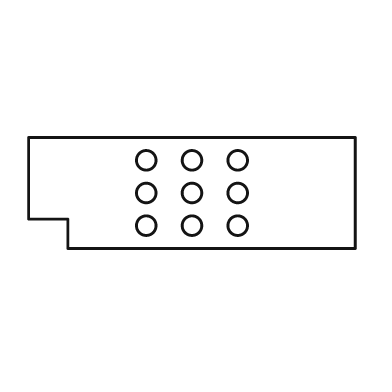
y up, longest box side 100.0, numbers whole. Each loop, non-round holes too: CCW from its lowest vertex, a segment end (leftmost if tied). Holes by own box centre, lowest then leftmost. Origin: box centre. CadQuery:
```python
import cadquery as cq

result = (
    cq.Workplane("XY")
    .moveTo(-38.0, -17.0)
    .lineTo(50.0, -17.0)
    .lineTo(50.0, 17.0)
    .lineTo(-50.0, 17.0)
    .lineTo(-50.0, -8.0)
    .lineTo(-38.0, -8.0)
    .close()
    .moveTo(-14.0, -10.0)
    .circle(3.0)
    .moveTo(0.0, -10.0)
    .circle(3.0)
    .moveTo(14.0, -10.0)
    .circle(3.0)
    .moveTo(-14.0, 0.0)
    .circle(3.0)
    .moveTo(0.0, 0.0)
    .circle(3.0)
    .moveTo(14.0, 0.0)
    .circle(3.0)
    .moveTo(-14.0, 10.0)
    .circle(3.0)
    .moveTo(0.0, 10.0)
    .circle(3.0)
    .moveTo(14.0, 10.0)
    .circle(3.0)
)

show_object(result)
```